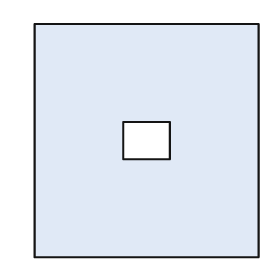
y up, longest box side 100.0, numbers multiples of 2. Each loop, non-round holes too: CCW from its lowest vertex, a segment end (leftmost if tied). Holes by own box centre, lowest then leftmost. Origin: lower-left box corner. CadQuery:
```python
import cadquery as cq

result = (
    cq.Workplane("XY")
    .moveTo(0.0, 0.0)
    .lineTo(96.0, 0.0)
    .lineTo(96.0, 100.0)
    .lineTo(0.0, 100.0)
    .close()
    .moveTo(38.0, 42.0)
    .lineTo(58.0, 42.0)
    .lineTo(58.0, 58.0)
    .lineTo(38.0, 58.0)
    .close()
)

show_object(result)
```